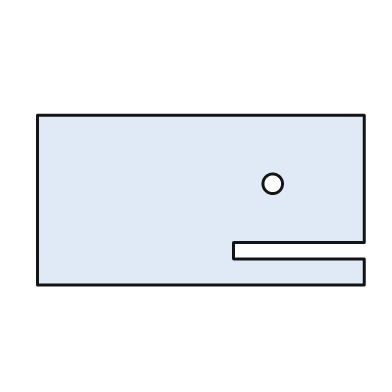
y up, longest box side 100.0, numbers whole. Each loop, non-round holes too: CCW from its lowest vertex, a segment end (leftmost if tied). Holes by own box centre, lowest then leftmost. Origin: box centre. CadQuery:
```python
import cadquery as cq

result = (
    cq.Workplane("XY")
    .moveTo(-50.0, -26.0)
    .lineTo(50.0, -26.0)
    .lineTo(50.0, -18.0)
    .lineTo(10.0, -18.0)
    .lineTo(10.0, -13.0)
    .lineTo(50.0, -13.0)
    .lineTo(50.0, 26.0)
    .lineTo(-50.0, 26.0)
    .close()
    .moveTo(22.0, 5.0)
    .circle(3.0)
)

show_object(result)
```